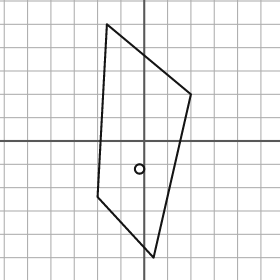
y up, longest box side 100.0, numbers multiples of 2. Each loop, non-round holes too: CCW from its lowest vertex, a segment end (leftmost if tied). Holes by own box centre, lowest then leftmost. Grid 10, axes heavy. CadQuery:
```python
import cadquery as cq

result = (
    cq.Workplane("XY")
    .moveTo(4.0, -50.0)
    .lineTo(20.0, 20.0)
    .lineTo(-16.0, 50.0)
    .lineTo(-20.0, -24.0)
    .close()
    .moveTo(-2.0, -12.0)
    .circle(2.0)
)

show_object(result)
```